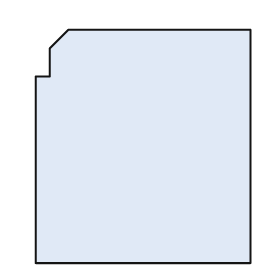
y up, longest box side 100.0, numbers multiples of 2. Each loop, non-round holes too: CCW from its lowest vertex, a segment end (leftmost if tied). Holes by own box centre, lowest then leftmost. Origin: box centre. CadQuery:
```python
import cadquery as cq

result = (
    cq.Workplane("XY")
    .moveTo(-46.0, -50.0)
    .lineTo(46.0, -50.0)
    .lineTo(46.0, 50.0)
    .lineTo(-32.0, 50.0)
    .lineTo(-40.0, 42.0)
    .lineTo(-40.0, 30.0)
    .lineTo(-46.0, 30.0)
    .close()
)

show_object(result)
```